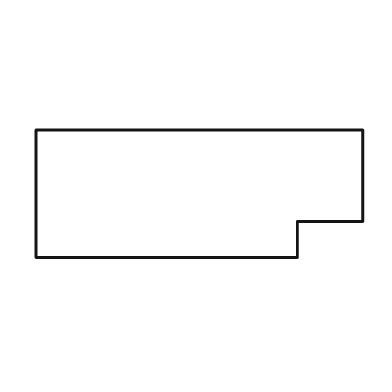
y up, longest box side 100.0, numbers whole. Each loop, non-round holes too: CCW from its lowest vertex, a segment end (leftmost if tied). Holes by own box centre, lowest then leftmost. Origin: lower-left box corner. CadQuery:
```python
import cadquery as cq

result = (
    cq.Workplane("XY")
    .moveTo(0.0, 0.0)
    .lineTo(80.0, 0.0)
    .lineTo(80.0, 11.0)
    .lineTo(100.0, 11.0)
    .lineTo(100.0, 39.0)
    .lineTo(0.0, 39.0)
    .close()
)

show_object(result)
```